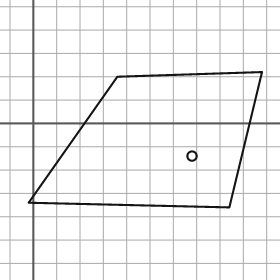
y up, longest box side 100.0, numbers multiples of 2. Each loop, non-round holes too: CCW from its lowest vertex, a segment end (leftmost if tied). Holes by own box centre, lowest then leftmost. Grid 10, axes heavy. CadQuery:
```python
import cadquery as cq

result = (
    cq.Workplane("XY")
    .moveTo(84.0, -36.0)
    .lineTo(98.0, 22.0)
    .lineTo(36.0, 20.0)
    .lineTo(-2.0, -34.0)
    .close()
    .moveTo(68.0, -14.0)
    .circle(2.0)
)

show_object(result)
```